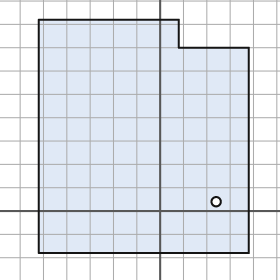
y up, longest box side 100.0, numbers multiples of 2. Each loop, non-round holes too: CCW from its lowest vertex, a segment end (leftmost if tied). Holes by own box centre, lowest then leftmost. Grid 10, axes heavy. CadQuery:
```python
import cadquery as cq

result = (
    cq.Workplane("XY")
    .moveTo(-52.0, -18.0)
    .lineTo(38.0, -18.0)
    .lineTo(38.0, 70.0)
    .lineTo(8.0, 70.0)
    .lineTo(8.0, 82.0)
    .lineTo(-52.0, 82.0)
    .close()
    .moveTo(24.0, 4.0)
    .circle(2.0)
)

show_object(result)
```